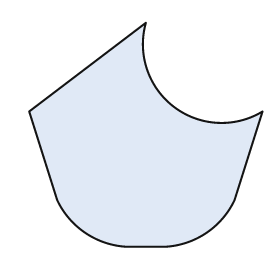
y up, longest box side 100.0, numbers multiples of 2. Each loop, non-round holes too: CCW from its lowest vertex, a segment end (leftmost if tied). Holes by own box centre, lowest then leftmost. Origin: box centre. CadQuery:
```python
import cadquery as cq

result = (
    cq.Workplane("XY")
    .moveTo(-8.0, -48.0)
    .lineTo(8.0, -48.0)
    .threePointArc((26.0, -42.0), (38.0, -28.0))
    .lineTo(50.0, 10.0)
    .threePointArc((12.0, 12.0), (0.0, 48.0))
    .lineTo(-50.0, 10.0)
    .lineTo(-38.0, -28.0)
    .threePointArc((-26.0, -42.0), (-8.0, -48.0))
    .close()
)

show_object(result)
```